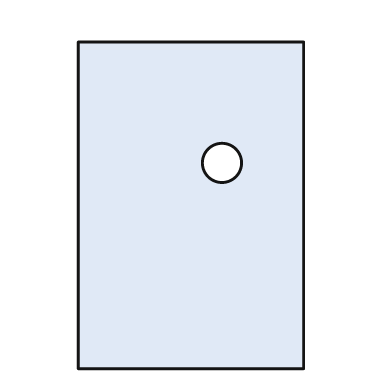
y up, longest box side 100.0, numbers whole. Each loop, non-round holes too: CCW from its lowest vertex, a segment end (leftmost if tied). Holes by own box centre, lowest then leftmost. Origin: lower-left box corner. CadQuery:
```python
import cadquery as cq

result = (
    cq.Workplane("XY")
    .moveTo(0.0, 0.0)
    .lineTo(69.0, 0.0)
    .lineTo(69.0, 100.0)
    .lineTo(0.0, 100.0)
    .close()
    .moveTo(44.0, 63.0)
    .circle(6.0)
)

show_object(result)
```